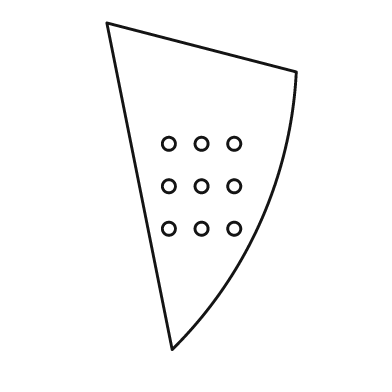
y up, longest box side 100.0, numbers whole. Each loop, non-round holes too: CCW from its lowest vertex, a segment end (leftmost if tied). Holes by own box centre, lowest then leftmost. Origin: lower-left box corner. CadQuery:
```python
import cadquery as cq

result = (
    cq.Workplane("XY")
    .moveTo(20.0, 0.0)
    .threePointArc((47.0, 39.0), (58.0, 85.0))
    .lineTo(0.0, 100.0)
    .close()
    .moveTo(19.0, 37.0)
    .circle(2.0)
    .moveTo(29.0, 37.0)
    .circle(2.0)
    .moveTo(39.0, 37.0)
    .circle(2.0)
    .moveTo(19.0, 50.0)
    .circle(2.0)
    .moveTo(29.0, 50.0)
    .circle(2.0)
    .moveTo(39.0, 50.0)
    .circle(2.0)
    .moveTo(19.0, 63.0)
    .circle(2.0)
    .moveTo(29.0, 63.0)
    .circle(2.0)
    .moveTo(39.0, 63.0)
    .circle(2.0)
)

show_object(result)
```